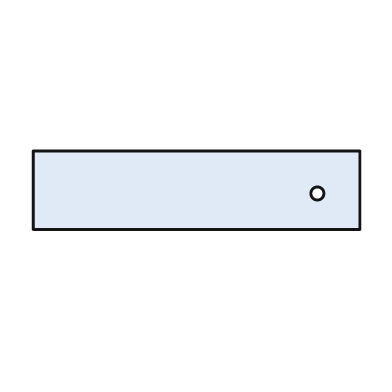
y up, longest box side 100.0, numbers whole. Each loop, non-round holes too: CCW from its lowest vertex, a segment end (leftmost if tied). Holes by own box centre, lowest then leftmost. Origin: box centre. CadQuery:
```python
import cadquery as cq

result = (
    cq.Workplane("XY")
    .moveTo(-50.0, -12.0)
    .lineTo(50.0, -12.0)
    .lineTo(50.0, 12.0)
    .lineTo(-50.0, 12.0)
    .close()
    .moveTo(37.0, -1.0)
    .circle(2.0)
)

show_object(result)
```